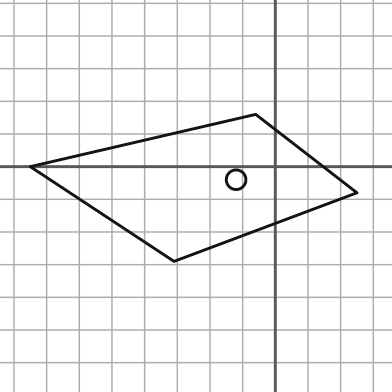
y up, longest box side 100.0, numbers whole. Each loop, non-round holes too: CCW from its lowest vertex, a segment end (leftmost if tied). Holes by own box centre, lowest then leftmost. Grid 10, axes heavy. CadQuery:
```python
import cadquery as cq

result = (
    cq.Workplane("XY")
    .moveTo(-31.0, -29.0)
    .lineTo(25.0, -8.0)
    .lineTo(-6.0, 16.0)
    .lineTo(-75.0, 0.0)
    .close()
    .moveTo(-12.0, -4.0)
    .circle(3.0)
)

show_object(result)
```